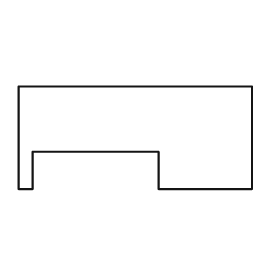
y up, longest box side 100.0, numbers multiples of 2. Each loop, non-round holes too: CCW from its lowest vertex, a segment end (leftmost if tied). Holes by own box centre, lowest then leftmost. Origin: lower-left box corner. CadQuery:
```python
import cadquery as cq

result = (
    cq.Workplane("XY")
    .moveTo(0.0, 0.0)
    .lineTo(6.0, 0.0)
    .lineTo(6.0, 16.0)
    .lineTo(60.0, 16.0)
    .lineTo(60.0, 0.0)
    .lineTo(100.0, 0.0)
    .lineTo(100.0, 44.0)
    .lineTo(0.0, 44.0)
    .close()
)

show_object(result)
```